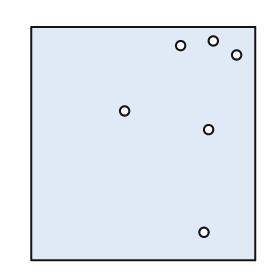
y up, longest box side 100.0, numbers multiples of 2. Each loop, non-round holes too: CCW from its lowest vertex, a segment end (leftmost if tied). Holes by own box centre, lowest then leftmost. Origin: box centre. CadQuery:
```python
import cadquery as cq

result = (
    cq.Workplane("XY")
    .moveTo(-48.0, -50.0)
    .lineTo(48.0, -50.0)
    .lineTo(48.0, 50.0)
    .lineTo(-48.0, 50.0)
    .close()
    .moveTo(26.0, -38.0)
    .circle(2.0)
    .moveTo(28.0, 6.0)
    .circle(2.0)
    .moveTo(-8.0, 14.0)
    .circle(2.0)
    .moveTo(40.0, 38.0)
    .circle(2.0)
    .moveTo(16.0, 42.0)
    .circle(2.0)
    .moveTo(30.0, 44.0)
    .circle(2.0)
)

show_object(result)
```